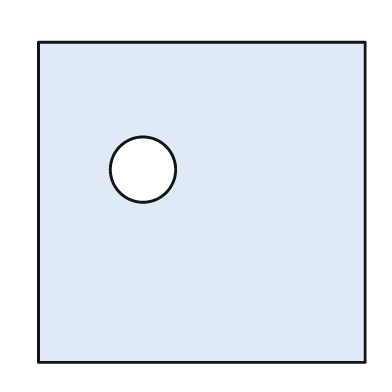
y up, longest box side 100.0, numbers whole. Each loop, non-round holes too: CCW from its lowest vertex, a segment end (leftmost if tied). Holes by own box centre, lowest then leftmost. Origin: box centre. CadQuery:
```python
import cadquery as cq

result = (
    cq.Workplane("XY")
    .moveTo(-50.0, -49.0)
    .lineTo(50.0, -49.0)
    .lineTo(50.0, 49.0)
    .lineTo(-50.0, 49.0)
    .close()
    .moveTo(-18.0, 10.0)
    .circle(10.0)
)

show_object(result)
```